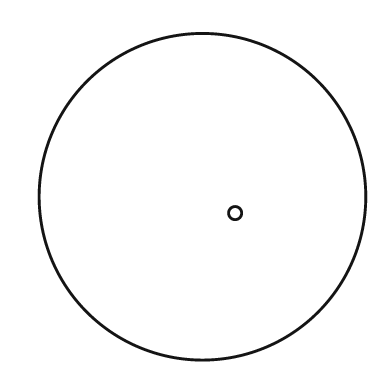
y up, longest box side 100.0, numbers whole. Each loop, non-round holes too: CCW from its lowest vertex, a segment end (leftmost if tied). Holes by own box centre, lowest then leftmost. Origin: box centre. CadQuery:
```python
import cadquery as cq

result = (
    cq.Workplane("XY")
    .moveTo(0.0, 0.0)
    .circle(50.0)
    .moveTo(10.0, -5.0)
    .circle(2.0)
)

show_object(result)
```